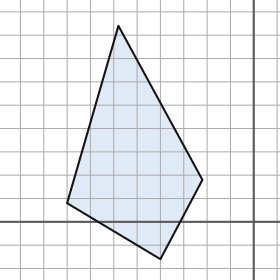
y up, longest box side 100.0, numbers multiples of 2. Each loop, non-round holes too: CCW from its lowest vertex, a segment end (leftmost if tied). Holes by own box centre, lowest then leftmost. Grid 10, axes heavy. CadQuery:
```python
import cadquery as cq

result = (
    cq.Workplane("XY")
    .moveTo(-40.0, -16.0)
    .lineTo(-22.0, 18.0)
    .lineTo(-58.0, 84.0)
    .lineTo(-80.0, 8.0)
    .close()
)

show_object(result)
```